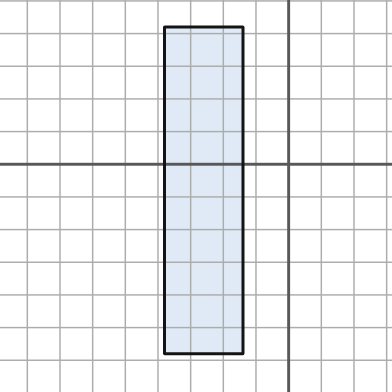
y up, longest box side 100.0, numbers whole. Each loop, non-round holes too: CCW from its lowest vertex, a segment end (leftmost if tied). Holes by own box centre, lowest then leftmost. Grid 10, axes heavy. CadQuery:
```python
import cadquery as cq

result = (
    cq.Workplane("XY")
    .moveTo(-38.0, -58.0)
    .lineTo(-14.0, -58.0)
    .lineTo(-14.0, 42.0)
    .lineTo(-38.0, 42.0)
    .close()
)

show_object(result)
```